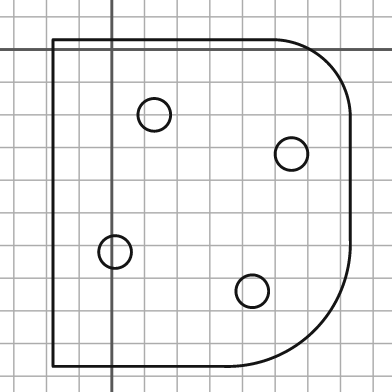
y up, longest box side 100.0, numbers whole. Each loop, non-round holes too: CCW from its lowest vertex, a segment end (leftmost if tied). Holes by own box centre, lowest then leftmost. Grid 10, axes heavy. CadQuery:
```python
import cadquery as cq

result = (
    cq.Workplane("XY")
    .moveTo(-18.0, -97.0)
    .lineTo(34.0, -97.0)
    .threePointArc((62.0, -86.0), (73.0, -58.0))
    .lineTo(73.0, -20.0)
    .threePointArc((66.0, -4.0), (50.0, 3.0))
    .lineTo(-18.0, 3.0)
    .close()
    .moveTo(43.0, -74.0)
    .circle(5.0)
    .moveTo(1.0, -62.0)
    .circle(5.0)
    .moveTo(55.0, -32.0)
    .circle(5.0)
    .moveTo(13.0, -20.0)
    .circle(5.0)
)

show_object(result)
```